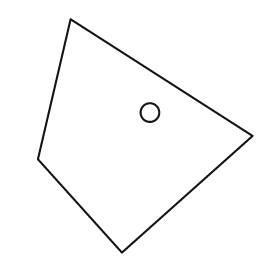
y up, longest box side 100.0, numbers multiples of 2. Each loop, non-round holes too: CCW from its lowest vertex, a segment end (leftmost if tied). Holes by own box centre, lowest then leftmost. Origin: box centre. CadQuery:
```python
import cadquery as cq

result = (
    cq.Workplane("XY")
    .moveTo(-10.0, -50.0)
    .lineTo(46.0, 0.0)
    .lineTo(-32.0, 50.0)
    .lineTo(-46.0, -10.0)
    .close()
    .moveTo(2.0, 10.0)
    .circle(4.0)
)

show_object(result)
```